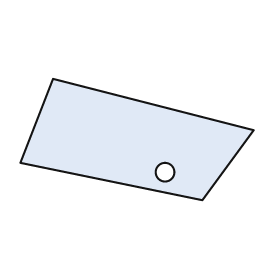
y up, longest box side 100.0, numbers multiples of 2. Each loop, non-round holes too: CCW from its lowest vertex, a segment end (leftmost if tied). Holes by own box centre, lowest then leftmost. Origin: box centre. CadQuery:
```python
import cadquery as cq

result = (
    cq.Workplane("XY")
    .moveTo(28.0, -26.0)
    .lineTo(50.0, 4.0)
    .lineTo(-36.0, 26.0)
    .lineTo(-50.0, -10.0)
    .close()
    .moveTo(12.0, -14.0)
    .circle(4.0)
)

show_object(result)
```